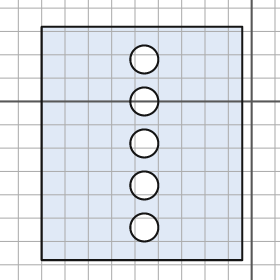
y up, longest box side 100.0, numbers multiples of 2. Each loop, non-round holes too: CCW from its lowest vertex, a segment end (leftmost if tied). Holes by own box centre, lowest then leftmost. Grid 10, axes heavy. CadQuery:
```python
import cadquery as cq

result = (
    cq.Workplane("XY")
    .moveTo(-90.0, -68.0)
    .lineTo(-4.0, -68.0)
    .lineTo(-4.0, 32.0)
    .lineTo(-90.0, 32.0)
    .close()
    .moveTo(-46.0, -54.0)
    .circle(6.0)
    .moveTo(-46.0, -36.0)
    .circle(6.0)
    .moveTo(-46.0, -18.0)
    .circle(6.0)
    .moveTo(-46.0, 0.0)
    .circle(6.0)
    .moveTo(-46.0, 18.0)
    .circle(6.0)
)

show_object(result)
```